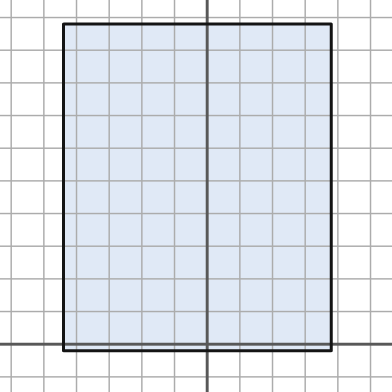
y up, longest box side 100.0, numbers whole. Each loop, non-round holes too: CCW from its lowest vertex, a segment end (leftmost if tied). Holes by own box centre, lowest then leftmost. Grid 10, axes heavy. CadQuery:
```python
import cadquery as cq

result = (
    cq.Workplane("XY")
    .moveTo(-44.0, -2.0)
    .lineTo(38.0, -2.0)
    .lineTo(38.0, 98.0)
    .lineTo(-44.0, 98.0)
    .close()
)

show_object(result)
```